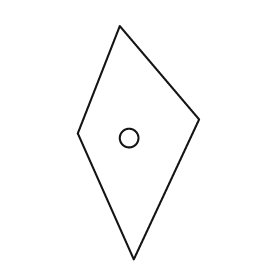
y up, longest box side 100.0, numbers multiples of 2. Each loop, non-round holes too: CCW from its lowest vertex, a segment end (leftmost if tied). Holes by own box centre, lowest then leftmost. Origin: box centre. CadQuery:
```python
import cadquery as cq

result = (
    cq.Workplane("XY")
    .moveTo(-2.0, -50.0)
    .lineTo(26.0, 10.0)
    .lineTo(-8.0, 50.0)
    .lineTo(-26.0, 4.0)
    .close()
    .moveTo(-4.0, 2.0)
    .circle(4.0)
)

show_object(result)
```